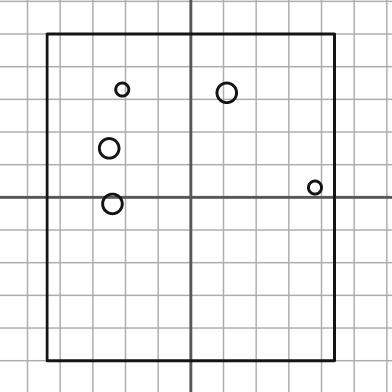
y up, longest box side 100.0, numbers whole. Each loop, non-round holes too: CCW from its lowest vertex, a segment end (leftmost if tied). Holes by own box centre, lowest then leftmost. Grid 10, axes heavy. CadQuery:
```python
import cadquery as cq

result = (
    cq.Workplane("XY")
    .moveTo(-44.0, -50.0)
    .lineTo(44.0, -50.0)
    .lineTo(44.0, 50.0)
    .lineTo(-44.0, 50.0)
    .close()
    .moveTo(-24.0, -2.0)
    .circle(3.0)
    .moveTo(38.0, 3.0)
    .circle(2.0)
    .moveTo(-25.0, 15.0)
    .circle(3.0)
    .moveTo(11.0, 32.0)
    .circle(3.0)
    .moveTo(-21.0, 33.0)
    .circle(2.0)
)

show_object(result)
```